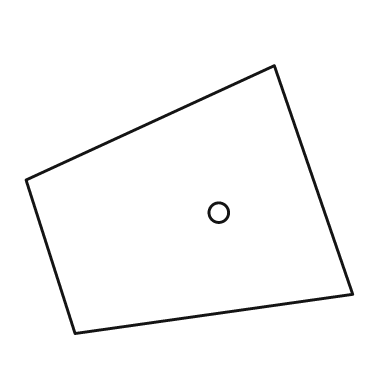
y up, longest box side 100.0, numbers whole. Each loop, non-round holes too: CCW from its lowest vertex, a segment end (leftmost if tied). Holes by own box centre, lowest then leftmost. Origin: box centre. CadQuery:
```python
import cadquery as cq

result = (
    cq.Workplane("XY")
    .moveTo(-35.0, -41.0)
    .lineTo(50.0, -29.0)
    .lineTo(26.0, 41.0)
    .lineTo(-50.0, 6.0)
    .close()
    .moveTo(9.0, -4.0)
    .circle(3.0)
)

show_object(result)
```